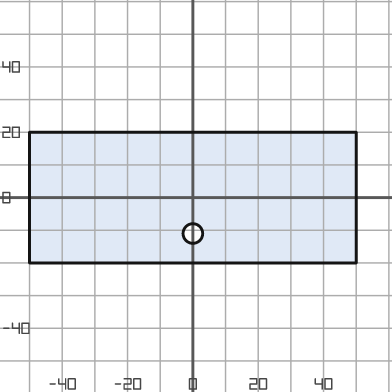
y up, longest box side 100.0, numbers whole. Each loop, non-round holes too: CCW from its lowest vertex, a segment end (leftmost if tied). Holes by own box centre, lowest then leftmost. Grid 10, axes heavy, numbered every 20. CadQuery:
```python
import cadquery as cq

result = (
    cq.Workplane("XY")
    .moveTo(-50.0, -20.0)
    .lineTo(50.0, -20.0)
    .lineTo(50.0, 20.0)
    .lineTo(-50.0, 20.0)
    .close()
    .moveTo(0.0, -11.0)
    .circle(3.0)
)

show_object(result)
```